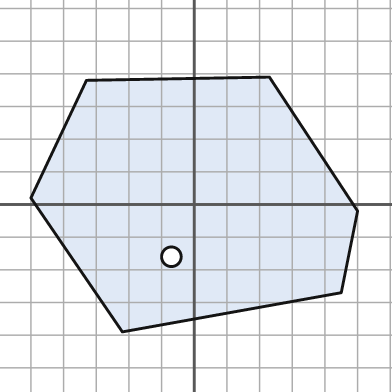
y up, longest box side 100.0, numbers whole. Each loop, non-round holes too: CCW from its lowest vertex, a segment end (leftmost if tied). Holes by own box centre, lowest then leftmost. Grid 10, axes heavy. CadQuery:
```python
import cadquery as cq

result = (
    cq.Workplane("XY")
    .moveTo(-22.0, -39.0)
    .lineTo(45.0, -27.0)
    .lineTo(50.0, -2.0)
    .lineTo(23.0, 39.0)
    .lineTo(-33.0, 38.0)
    .lineTo(-50.0, 2.0)
    .close()
    .moveTo(-7.0, -16.0)
    .circle(3.0)
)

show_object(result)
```